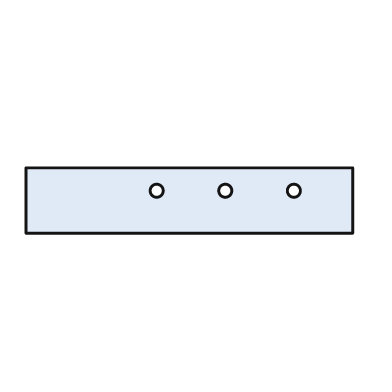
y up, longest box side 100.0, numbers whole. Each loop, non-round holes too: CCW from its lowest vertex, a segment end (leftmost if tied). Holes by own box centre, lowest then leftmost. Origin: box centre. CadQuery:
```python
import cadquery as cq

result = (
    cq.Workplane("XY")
    .moveTo(-50.0, -10.0)
    .lineTo(50.0, -10.0)
    .lineTo(50.0, 10.0)
    .lineTo(-50.0, 10.0)
    .close()
    .moveTo(-10.0, 3.0)
    .circle(2.0)
    .moveTo(11.0, 3.0)
    .circle(2.0)
    .moveTo(32.0, 3.0)
    .circle(2.0)
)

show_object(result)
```